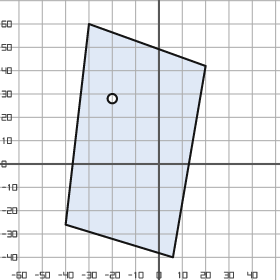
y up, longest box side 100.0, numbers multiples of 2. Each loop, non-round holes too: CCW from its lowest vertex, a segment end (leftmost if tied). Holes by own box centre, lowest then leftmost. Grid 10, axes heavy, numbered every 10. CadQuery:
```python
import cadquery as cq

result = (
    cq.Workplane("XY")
    .moveTo(6.0, -40.0)
    .lineTo(20.0, 42.0)
    .lineTo(-30.0, 60.0)
    .lineTo(-40.0, -26.0)
    .close()
    .moveTo(-20.0, 28.0)
    .circle(2.0)
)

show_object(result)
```